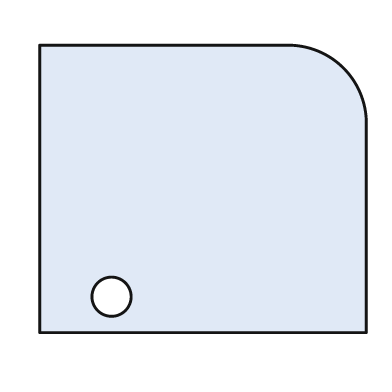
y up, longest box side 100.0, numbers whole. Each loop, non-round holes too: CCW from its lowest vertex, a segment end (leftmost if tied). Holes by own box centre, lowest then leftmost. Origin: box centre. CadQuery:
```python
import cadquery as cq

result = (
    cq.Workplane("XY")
    .moveTo(-50.0, -44.0)
    .lineTo(50.0, -44.0)
    .lineTo(50.0, 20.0)
    .threePointArc((43.0, 37.0), (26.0, 44.0))
    .lineTo(-50.0, 44.0)
    .close()
    .moveTo(-28.0, -33.0)
    .circle(6.0)
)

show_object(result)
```